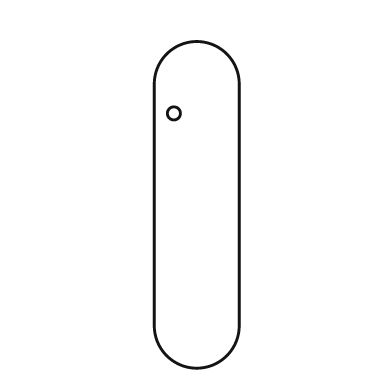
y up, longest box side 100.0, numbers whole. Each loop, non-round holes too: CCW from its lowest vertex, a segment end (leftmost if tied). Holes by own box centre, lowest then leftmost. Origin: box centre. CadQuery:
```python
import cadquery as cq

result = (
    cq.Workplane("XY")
    .moveTo(-13.0, -37.0)
    .threePointArc((0.0, -50.0), (13.0, -37.0))
    .lineTo(13.0, 37.0)
    .threePointArc((0.0, 50.0), (-13.0, 37.0))
    .close()
    .moveTo(-7.0, 28.0)
    .circle(2.0)
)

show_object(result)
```